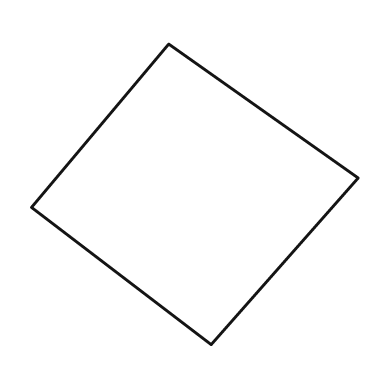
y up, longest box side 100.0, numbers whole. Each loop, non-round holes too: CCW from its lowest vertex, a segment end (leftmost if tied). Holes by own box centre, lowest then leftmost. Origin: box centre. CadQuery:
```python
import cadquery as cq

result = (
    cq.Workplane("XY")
    .moveTo(5.0, -46.0)
    .lineTo(50.0, 5.0)
    .lineTo(-8.0, 46.0)
    .lineTo(-50.0, -4.0)
    .close()
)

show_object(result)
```